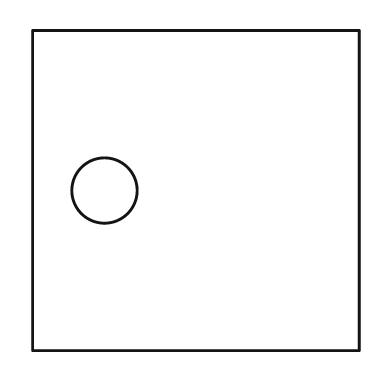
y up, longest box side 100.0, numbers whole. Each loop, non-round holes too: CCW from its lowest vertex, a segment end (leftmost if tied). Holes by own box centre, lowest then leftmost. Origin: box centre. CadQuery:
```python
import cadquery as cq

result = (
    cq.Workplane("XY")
    .moveTo(-50.0, -49.0)
    .lineTo(50.0, -49.0)
    .lineTo(50.0, 49.0)
    .lineTo(-50.0, 49.0)
    .close()
    .moveTo(-28.0, 0.0)
    .circle(10.0)
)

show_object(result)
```